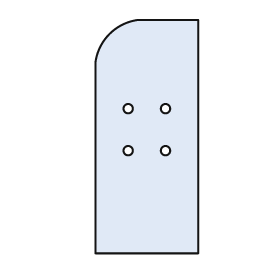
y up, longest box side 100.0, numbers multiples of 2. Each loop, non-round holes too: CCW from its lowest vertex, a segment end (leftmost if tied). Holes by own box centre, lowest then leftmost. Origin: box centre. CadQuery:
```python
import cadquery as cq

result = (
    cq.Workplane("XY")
    .moveTo(-22.0, -50.0)
    .lineTo(22.0, -50.0)
    .lineTo(22.0, 50.0)
    .lineTo(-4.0, 50.0)
    .threePointArc((-16.0, 44.0), (-22.0, 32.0))
    .close()
    .moveTo(-8.0, -6.0)
    .circle(2.0)
    .moveTo(8.0, -6.0)
    .circle(2.0)
    .moveTo(-8.0, 12.0)
    .circle(2.0)
    .moveTo(8.0, 12.0)
    .circle(2.0)
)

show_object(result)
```